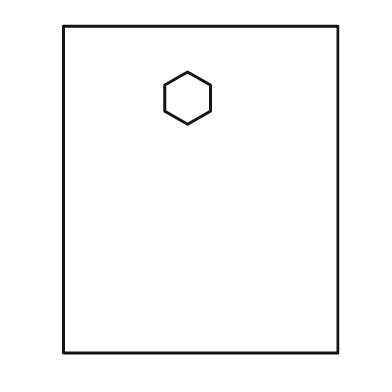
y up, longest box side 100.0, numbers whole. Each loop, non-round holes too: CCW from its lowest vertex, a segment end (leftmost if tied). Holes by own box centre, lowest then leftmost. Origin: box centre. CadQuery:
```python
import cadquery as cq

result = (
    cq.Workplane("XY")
    .moveTo(-42.0, -50.0)
    .lineTo(42.0, -50.0)
    .lineTo(42.0, 50.0)
    .lineTo(-42.0, 50.0)
    .close()
    .moveTo(-4.0, 20.0)
    .lineTo(3.0, 24.0)
    .lineTo(3.0, 32.0)
    .lineTo(-4.0, 36.0)
    .lineTo(-11.0, 32.0)
    .lineTo(-11.0, 24.0)
    .close()
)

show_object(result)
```